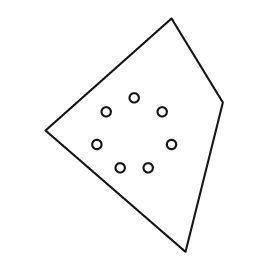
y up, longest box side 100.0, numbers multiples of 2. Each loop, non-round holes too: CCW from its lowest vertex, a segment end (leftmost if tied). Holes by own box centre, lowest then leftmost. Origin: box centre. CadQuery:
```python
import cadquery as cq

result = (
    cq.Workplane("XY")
    .moveTo(22.0, -50.0)
    .lineTo(38.0, 14.0)
    .lineTo(16.0, 50.0)
    .lineTo(-38.0, 2.0)
    .close()
    .moveTo(-6.0, -14.0)
    .circle(2.0)
    .moveTo(6.0, -14.0)
    .circle(2.0)
    .moveTo(-16.0, -4.0)
    .circle(2.0)
    .moveTo(16.0, -4.0)
    .circle(2.0)
    .moveTo(-12.0, 10.0)
    .circle(2.0)
    .moveTo(12.0, 10.0)
    .circle(2.0)
    .moveTo(0.0, 16.0)
    .circle(2.0)
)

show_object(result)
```